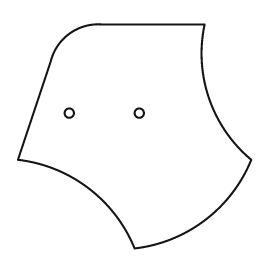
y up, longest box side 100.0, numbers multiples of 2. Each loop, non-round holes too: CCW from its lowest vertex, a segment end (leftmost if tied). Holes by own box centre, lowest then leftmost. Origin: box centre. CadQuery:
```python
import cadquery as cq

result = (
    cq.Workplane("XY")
    .moveTo(0.0, -48.0)
    .threePointArc((30.0, -36.0), (50.0, -10.0))
    .threePointArc((32.0, 16.0), (30.0, 48.0))
    .lineTo(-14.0, 48.0)
    .threePointArc((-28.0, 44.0), (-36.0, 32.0))
    .lineTo(-50.0, -10.0)
    .threePointArc((-20.0, -22.0), (0.0, -48.0))
    .close()
    .moveTo(-28.0, 10.0)
    .circle(2.0)
    .moveTo(2.0, 10.0)
    .circle(2.0)
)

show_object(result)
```